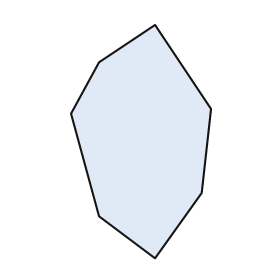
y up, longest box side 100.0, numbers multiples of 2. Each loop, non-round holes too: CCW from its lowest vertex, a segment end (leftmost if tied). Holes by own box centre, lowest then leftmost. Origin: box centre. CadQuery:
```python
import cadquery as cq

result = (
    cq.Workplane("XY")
    .moveTo(6.0, -50.0)
    .lineTo(26.0, -22.0)
    .lineTo(30.0, 14.0)
    .lineTo(6.0, 50.0)
    .lineTo(-18.0, 34.0)
    .lineTo(-30.0, 12.0)
    .lineTo(-18.0, -32.0)
    .close()
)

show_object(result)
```